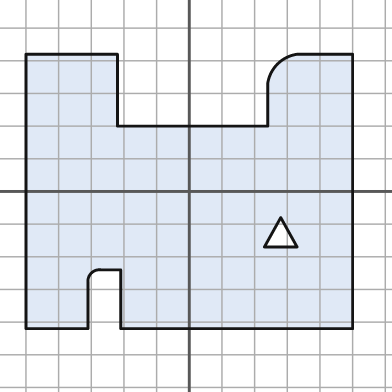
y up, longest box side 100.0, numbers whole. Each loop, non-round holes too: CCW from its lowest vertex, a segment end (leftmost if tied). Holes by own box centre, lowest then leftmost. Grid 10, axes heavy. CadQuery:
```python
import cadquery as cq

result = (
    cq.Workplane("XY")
    .moveTo(-50.0, -42.0)
    .lineTo(-31.0, -42.0)
    .lineTo(-31.0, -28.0)
    .threePointArc((-30.0, -25.0), (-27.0, -24.0))
    .lineTo(-21.0, -24.0)
    .lineTo(-21.0, -42.0)
    .lineTo(50.0, -42.0)
    .lineTo(50.0, 42.0)
    .lineTo(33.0, 42.0)
    .threePointArc((27.0, 39.0), (24.0, 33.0))
    .lineTo(24.0, 20.0)
    .lineTo(-22.0, 20.0)
    .lineTo(-22.0, 42.0)
    .lineTo(-50.0, 42.0)
    .close()
    .moveTo(23.0, -17.0)
    .lineTo(33.0, -17.0)
    .lineTo(28.0, -8.0)
    .close()
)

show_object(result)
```